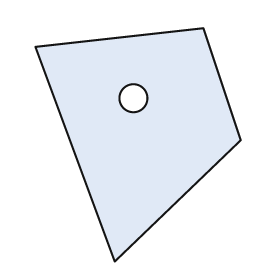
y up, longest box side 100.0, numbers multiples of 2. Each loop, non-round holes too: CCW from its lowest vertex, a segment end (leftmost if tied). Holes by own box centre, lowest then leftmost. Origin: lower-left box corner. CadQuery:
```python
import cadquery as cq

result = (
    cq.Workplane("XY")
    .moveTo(34.0, 0.0)
    .lineTo(88.0, 52.0)
    .lineTo(72.0, 100.0)
    .lineTo(0.0, 92.0)
    .close()
    .moveTo(42.0, 70.0)
    .circle(6.0)
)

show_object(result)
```